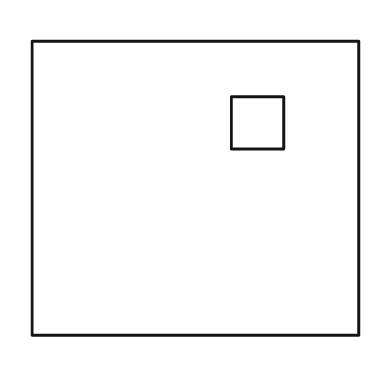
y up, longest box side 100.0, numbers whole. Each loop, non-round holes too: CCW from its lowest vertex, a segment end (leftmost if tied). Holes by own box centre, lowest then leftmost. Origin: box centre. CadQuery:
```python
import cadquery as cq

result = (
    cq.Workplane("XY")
    .moveTo(-50.0, -45.0)
    .lineTo(50.0, -45.0)
    .lineTo(50.0, 45.0)
    .lineTo(-50.0, 45.0)
    .close()
    .moveTo(11.0, 12.0)
    .lineTo(27.0, 12.0)
    .lineTo(27.0, 28.0)
    .lineTo(11.0, 28.0)
    .close()
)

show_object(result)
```